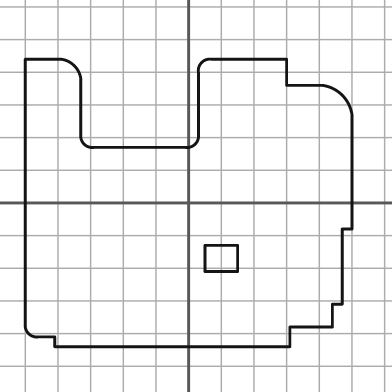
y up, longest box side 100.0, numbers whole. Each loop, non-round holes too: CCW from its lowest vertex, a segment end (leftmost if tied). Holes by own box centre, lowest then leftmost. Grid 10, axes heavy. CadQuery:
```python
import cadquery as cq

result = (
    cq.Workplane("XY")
    .moveTo(-41.0, -44.0)
    .lineTo(31.0, -44.0)
    .lineTo(31.0, -38.0)
    .lineTo(44.0, -38.0)
    .lineTo(44.0, -31.0)
    .lineTo(47.0, -31.0)
    .lineTo(47.0, -8.0)
    .lineTo(50.0, -8.0)
    .lineTo(50.0, 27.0)
    .threePointArc((47.0, 33.0), (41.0, 36.0))
    .lineTo(30.0, 36.0)
    .lineTo(30.0, 44.0)
    .lineTo(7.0, 44.0)
    .threePointArc((4.0, 43.0), (3.0, 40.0))
    .lineTo(3.0, 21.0)
    .threePointArc((2.0, 18.0), (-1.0, 17.0))
    .lineTo(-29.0, 17.0)
    .threePointArc((-32.0, 18.0), (-33.0, 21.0))
    .lineTo(-33.0, 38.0)
    .threePointArc((-35.0, 42.0), (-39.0, 44.0))
    .lineTo(-50.0, 44.0)
    .lineTo(-50.0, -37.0)
    .threePointArc((-49.0, -40.0), (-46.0, -41.0))
    .lineTo(-41.0, -41.0)
    .close()
    .moveTo(5.0, -21.0)
    .lineTo(15.0, -21.0)
    .lineTo(15.0, -13.0)
    .lineTo(5.0, -13.0)
    .close()
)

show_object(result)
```